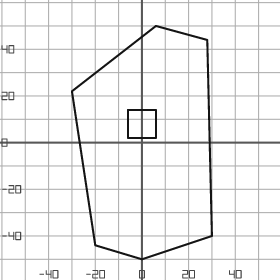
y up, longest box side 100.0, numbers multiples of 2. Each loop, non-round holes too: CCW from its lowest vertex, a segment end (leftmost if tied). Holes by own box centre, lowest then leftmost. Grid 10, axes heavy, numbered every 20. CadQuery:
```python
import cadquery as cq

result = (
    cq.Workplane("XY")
    .moveTo(0.0, -50.0)
    .lineTo(30.0, -40.0)
    .lineTo(28.0, 44.0)
    .lineTo(6.0, 50.0)
    .lineTo(-30.0, 22.0)
    .lineTo(-20.0, -44.0)
    .close()
    .moveTo(-6.0, 2.0)
    .lineTo(6.0, 2.0)
    .lineTo(6.0, 14.0)
    .lineTo(-6.0, 14.0)
    .close()
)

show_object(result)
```